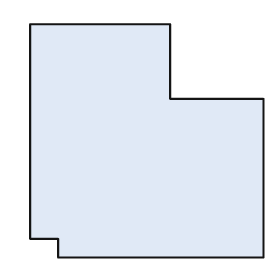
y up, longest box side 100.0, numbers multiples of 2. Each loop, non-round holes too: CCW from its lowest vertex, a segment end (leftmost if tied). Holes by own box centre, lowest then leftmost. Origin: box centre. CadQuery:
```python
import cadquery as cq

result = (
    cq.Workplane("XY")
    .moveTo(-38.0, -50.0)
    .lineTo(50.0, -50.0)
    .lineTo(50.0, 18.0)
    .lineTo(10.0, 18.0)
    .lineTo(10.0, 50.0)
    .lineTo(-50.0, 50.0)
    .lineTo(-50.0, -42.0)
    .lineTo(-38.0, -42.0)
    .close()
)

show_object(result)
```